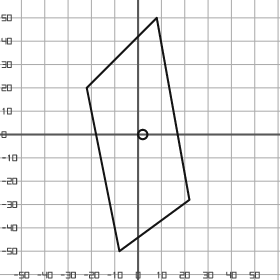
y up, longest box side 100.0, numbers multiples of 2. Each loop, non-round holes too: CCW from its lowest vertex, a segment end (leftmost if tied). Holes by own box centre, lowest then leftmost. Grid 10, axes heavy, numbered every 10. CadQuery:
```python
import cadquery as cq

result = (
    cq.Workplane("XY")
    .moveTo(-8.0, -50.0)
    .lineTo(22.0, -28.0)
    .lineTo(8.0, 50.0)
    .lineTo(-22.0, 20.0)
    .close()
    .moveTo(2.0, 0.0)
    .circle(2.0)
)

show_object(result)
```